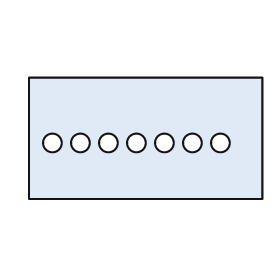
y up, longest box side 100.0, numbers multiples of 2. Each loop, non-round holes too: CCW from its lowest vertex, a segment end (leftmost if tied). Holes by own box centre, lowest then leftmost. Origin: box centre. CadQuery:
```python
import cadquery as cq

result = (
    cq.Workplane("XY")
    .moveTo(-50.0, -26.0)
    .lineTo(50.0, -26.0)
    .lineTo(50.0, 26.0)
    .lineTo(-50.0, 26.0)
    .close()
    .moveTo(-40.0, -2.0)
    .circle(4.0)
    .moveTo(-28.0, -2.0)
    .circle(4.0)
    .moveTo(-16.0, -2.0)
    .circle(4.0)
    .moveTo(-4.0, -2.0)
    .circle(4.0)
    .moveTo(8.0, -2.0)
    .circle(4.0)
    .moveTo(20.0, -2.0)
    .circle(4.0)
    .moveTo(32.0, -2.0)
    .circle(4.0)
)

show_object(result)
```